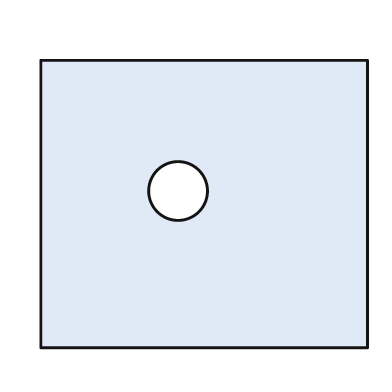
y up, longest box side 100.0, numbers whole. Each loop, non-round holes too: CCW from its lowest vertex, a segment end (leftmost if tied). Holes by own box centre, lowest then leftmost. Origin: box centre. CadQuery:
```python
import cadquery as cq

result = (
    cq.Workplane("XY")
    .moveTo(-50.0, -44.0)
    .lineTo(50.0, -44.0)
    .lineTo(50.0, 44.0)
    .lineTo(-50.0, 44.0)
    .close()
    .moveTo(-8.0, 4.0)
    .circle(9.0)
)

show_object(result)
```